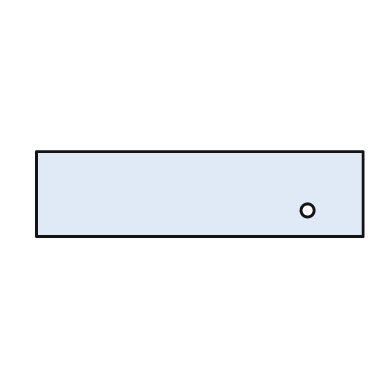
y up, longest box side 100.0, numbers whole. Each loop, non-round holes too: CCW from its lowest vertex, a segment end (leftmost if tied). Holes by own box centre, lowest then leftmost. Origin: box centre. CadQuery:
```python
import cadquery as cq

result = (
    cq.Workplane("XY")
    .moveTo(-50.0, -13.0)
    .lineTo(50.0, -13.0)
    .lineTo(50.0, 13.0)
    .lineTo(-50.0, 13.0)
    .close()
    .moveTo(33.0, -5.0)
    .circle(2.0)
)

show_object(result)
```